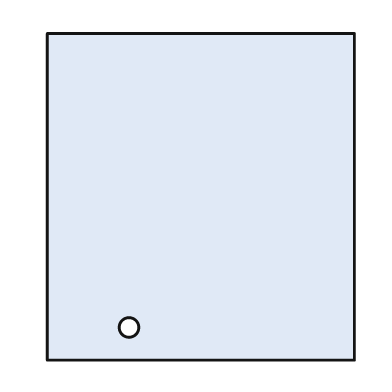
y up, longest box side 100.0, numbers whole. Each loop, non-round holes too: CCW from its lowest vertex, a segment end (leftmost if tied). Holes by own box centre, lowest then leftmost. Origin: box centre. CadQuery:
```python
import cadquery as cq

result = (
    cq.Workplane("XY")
    .moveTo(-47.0, -50.0)
    .lineTo(47.0, -50.0)
    .lineTo(47.0, 50.0)
    .lineTo(-47.0, 50.0)
    .close()
    .moveTo(-22.0, -40.0)
    .circle(3.0)
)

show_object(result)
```